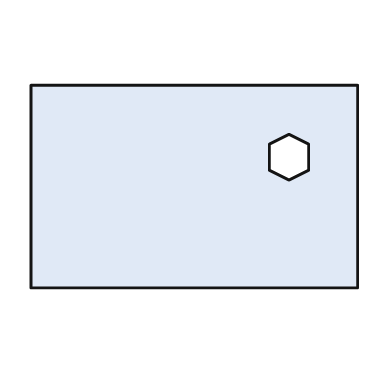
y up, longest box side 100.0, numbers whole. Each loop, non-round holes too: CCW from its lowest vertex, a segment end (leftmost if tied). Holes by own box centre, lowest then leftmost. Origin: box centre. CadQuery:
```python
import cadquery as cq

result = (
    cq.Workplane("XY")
    .moveTo(-50.0, -31.0)
    .lineTo(50.0, -31.0)
    .lineTo(50.0, 31.0)
    .lineTo(-50.0, 31.0)
    .close()
    .moveTo(29.0, 2.0)
    .lineTo(35.0, 5.0)
    .lineTo(35.0, 13.0)
    .lineTo(29.0, 16.0)
    .lineTo(23.0, 13.0)
    .lineTo(23.0, 5.0)
    .close()
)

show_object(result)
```